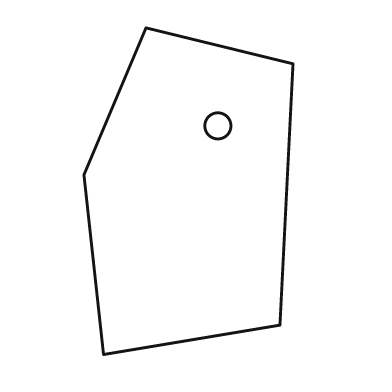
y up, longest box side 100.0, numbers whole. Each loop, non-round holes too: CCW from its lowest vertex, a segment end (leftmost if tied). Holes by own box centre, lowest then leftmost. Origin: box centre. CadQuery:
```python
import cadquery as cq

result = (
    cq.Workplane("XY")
    .moveTo(-26.0, -50.0)
    .lineTo(28.0, -41.0)
    .lineTo(32.0, 39.0)
    .lineTo(-13.0, 50.0)
    .lineTo(-32.0, 5.0)
    .close()
    .moveTo(9.0, 20.0)
    .circle(4.0)
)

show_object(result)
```